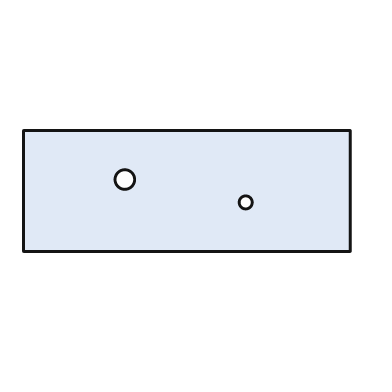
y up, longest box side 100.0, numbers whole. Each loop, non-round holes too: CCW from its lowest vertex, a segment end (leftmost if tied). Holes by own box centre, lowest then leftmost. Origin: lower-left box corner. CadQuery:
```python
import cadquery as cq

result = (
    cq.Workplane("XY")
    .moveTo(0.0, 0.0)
    .lineTo(100.0, 0.0)
    .lineTo(100.0, 37.0)
    .lineTo(0.0, 37.0)
    .close()
    .moveTo(68.0, 15.0)
    .circle(2.0)
    .moveTo(31.0, 22.0)
    .circle(3.0)
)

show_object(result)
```